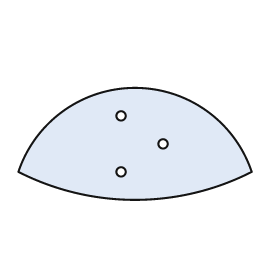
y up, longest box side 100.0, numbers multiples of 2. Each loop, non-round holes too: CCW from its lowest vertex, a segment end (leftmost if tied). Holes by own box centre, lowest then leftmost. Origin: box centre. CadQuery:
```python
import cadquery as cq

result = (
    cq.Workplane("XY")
    .moveTo(-50.0, -12.0)
    .threePointArc((0.0, -24.0), (50.0, -12.0))
    .threePointArc((0.0, 24.0), (-50.0, -12.0))
    .close()
    .moveTo(-6.0, -12.0)
    .circle(2.0)
    .moveTo(12.0, 0.0)
    .circle(2.0)
    .moveTo(-6.0, 12.0)
    .circle(2.0)
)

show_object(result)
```